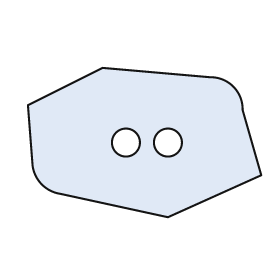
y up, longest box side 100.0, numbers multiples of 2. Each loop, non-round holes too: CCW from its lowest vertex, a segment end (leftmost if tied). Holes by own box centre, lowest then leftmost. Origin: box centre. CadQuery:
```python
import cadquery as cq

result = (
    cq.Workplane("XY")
    .moveTo(10.0, -32.0)
    .lineTo(50.0, -14.0)
    .lineTo(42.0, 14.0)
    .threePointArc((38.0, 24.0), (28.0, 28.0))
    .lineTo(-18.0, 32.0)
    .lineTo(-50.0, 16.0)
    .lineTo(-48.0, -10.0)
    .threePointArc((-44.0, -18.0), (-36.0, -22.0))
    .close()
    .moveTo(-8.0, 0.0)
    .circle(6.0)
    .moveTo(10.0, 0.0)
    .circle(6.0)
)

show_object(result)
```